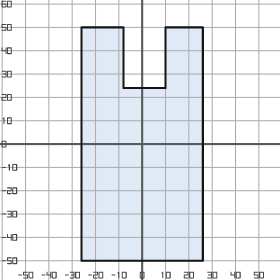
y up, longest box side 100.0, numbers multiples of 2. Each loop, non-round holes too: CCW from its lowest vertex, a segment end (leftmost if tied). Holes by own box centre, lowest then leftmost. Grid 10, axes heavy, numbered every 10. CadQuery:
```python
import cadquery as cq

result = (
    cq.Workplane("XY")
    .moveTo(-26.0, -50.0)
    .lineTo(26.0, -50.0)
    .lineTo(26.0, 50.0)
    .lineTo(10.0, 50.0)
    .lineTo(10.0, 24.0)
    .lineTo(-8.0, 24.0)
    .lineTo(-8.0, 50.0)
    .lineTo(-26.0, 50.0)
    .close()
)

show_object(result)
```